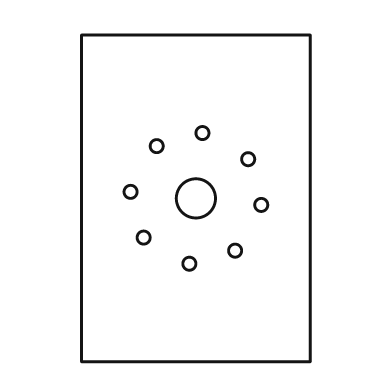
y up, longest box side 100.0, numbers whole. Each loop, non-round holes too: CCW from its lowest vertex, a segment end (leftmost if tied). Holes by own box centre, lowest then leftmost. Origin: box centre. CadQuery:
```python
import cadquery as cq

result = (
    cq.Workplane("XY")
    .moveTo(-35.0, -50.0)
    .lineTo(35.0, -50.0)
    .lineTo(35.0, 50.0)
    .lineTo(-35.0, 50.0)
    .close()
    .moveTo(-2.0, -20.0)
    .circle(2.0)
    .moveTo(12.0, -16.0)
    .circle(2.0)
    .moveTo(-16.0, -12.0)
    .circle(2.0)
    .moveTo(20.0, -2.0)
    .circle(2.0)
    .moveTo(0.0, 0.0)
    .circle(6.0)
    .moveTo(-20.0, 2.0)
    .circle(2.0)
    .moveTo(16.0, 12.0)
    .circle(2.0)
    .moveTo(-12.0, 16.0)
    .circle(2.0)
    .moveTo(2.0, 20.0)
    .circle(2.0)
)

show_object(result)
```